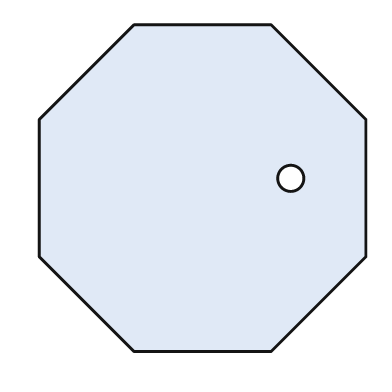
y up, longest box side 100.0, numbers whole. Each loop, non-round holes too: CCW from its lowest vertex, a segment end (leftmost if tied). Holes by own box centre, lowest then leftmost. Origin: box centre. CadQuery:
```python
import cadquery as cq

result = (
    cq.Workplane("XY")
    .moveTo(-21.0, -50.0)
    .lineTo(21.0, -50.0)
    .lineTo(50.0, -21.0)
    .lineTo(50.0, 21.0)
    .lineTo(21.0, 50.0)
    .lineTo(-21.0, 50.0)
    .lineTo(-50.0, 21.0)
    .lineTo(-50.0, -21.0)
    .close()
    .moveTo(27.0, 3.0)
    .circle(4.0)
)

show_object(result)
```